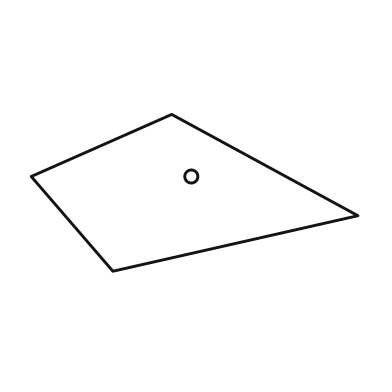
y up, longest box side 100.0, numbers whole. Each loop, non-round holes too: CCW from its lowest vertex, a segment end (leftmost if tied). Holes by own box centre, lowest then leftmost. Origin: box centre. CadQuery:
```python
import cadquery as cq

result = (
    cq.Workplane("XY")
    .moveTo(-25.0, -24.0)
    .lineTo(50.0, -7.0)
    .lineTo(-7.0, 24.0)
    .lineTo(-50.0, 5.0)
    .close()
    .moveTo(-1.0, 5.0)
    .circle(2.0)
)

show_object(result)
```